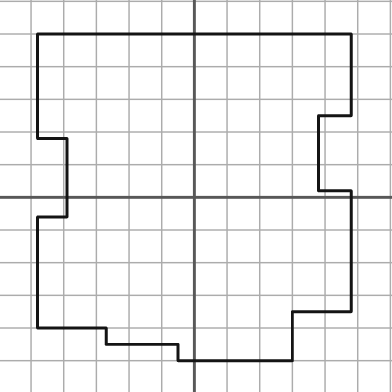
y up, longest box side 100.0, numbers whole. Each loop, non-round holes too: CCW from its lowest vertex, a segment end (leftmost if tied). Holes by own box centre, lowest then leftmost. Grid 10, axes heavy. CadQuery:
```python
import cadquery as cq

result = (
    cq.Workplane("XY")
    .moveTo(-5.0, -50.0)
    .lineTo(30.0, -50.0)
    .lineTo(30.0, -35.0)
    .lineTo(48.0, -35.0)
    .lineTo(48.0, 2.0)
    .lineTo(38.0, 2.0)
    .lineTo(38.0, 25.0)
    .lineTo(48.0, 25.0)
    .lineTo(48.0, 50.0)
    .lineTo(-48.0, 50.0)
    .lineTo(-48.0, 18.0)
    .lineTo(-39.0, 18.0)
    .lineTo(-39.0, -6.0)
    .lineTo(-48.0, -6.0)
    .lineTo(-48.0, -40.0)
    .lineTo(-27.0, -40.0)
    .lineTo(-27.0, -45.0)
    .lineTo(-5.0, -45.0)
    .close()
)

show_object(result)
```